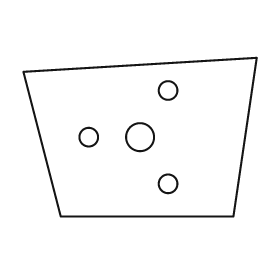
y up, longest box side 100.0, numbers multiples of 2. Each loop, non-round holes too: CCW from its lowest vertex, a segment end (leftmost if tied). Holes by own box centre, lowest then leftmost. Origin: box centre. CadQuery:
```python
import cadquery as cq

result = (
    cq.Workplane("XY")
    .moveTo(-34.0, -34.0)
    .lineTo(40.0, -34.0)
    .lineTo(50.0, 34.0)
    .lineTo(-50.0, 28.0)
    .close()
    .moveTo(12.0, -20.0)
    .circle(4.0)
    .moveTo(-22.0, 0.0)
    .circle(4.0)
    .moveTo(0.0, 0.0)
    .circle(6.0)
    .moveTo(12.0, 20.0)
    .circle(4.0)
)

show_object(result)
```